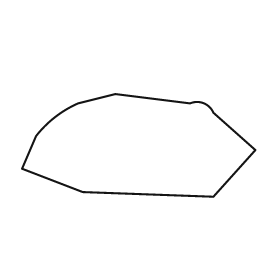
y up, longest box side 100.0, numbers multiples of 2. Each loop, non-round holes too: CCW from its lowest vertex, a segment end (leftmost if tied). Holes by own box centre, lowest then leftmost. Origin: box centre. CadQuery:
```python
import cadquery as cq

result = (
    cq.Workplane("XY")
    .moveTo(32.0, -22.0)
    .lineTo(50.0, -2.0)
    .lineTo(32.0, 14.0)
    .threePointArc((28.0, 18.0), (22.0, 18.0))
    .lineTo(-10.0, 22.0)
    .lineTo(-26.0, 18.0)
    .threePointArc((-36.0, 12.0), (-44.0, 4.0))
    .lineTo(-50.0, -10.0)
    .lineTo(-24.0, -20.0)
    .close()
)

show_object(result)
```